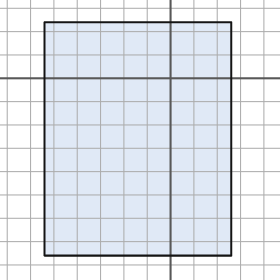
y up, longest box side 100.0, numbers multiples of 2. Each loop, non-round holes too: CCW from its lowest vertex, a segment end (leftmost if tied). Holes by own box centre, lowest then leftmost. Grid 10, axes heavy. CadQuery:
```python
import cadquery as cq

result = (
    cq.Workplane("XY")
    .moveTo(-54.0, -76.0)
    .lineTo(26.0, -76.0)
    .lineTo(26.0, 24.0)
    .lineTo(-54.0, 24.0)
    .close()
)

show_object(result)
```